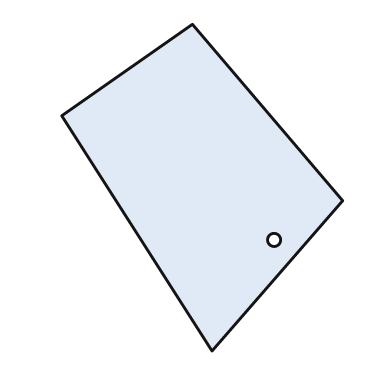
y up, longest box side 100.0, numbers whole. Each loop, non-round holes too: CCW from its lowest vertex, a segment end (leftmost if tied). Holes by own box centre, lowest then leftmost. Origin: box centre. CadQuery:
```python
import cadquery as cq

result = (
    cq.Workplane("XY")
    .moveTo(3.0, -50.0)
    .lineTo(43.0, -4.0)
    .lineTo(-3.0, 50.0)
    .lineTo(-43.0, 22.0)
    .close()
    .moveTo(22.0, -16.0)
    .circle(2.0)
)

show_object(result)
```